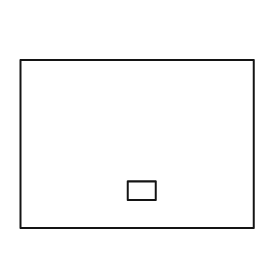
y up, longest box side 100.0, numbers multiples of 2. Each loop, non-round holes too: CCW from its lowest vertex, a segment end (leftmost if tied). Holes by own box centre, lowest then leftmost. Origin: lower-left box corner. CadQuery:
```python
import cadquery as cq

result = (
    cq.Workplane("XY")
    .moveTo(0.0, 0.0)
    .lineTo(100.0, 0.0)
    .lineTo(100.0, 72.0)
    .lineTo(0.0, 72.0)
    .close()
    .moveTo(46.0, 12.0)
    .lineTo(58.0, 12.0)
    .lineTo(58.0, 20.0)
    .lineTo(46.0, 20.0)
    .close()
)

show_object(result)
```